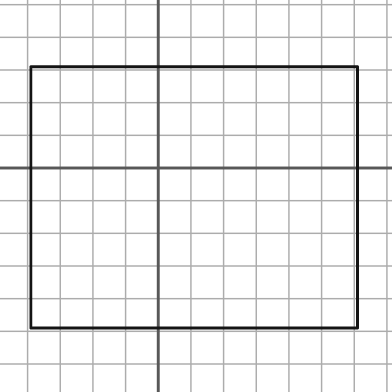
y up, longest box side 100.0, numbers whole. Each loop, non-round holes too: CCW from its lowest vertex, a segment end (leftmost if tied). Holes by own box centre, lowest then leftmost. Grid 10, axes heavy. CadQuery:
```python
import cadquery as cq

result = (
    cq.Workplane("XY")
    .moveTo(-39.0, -49.0)
    .lineTo(61.0, -49.0)
    .lineTo(61.0, 31.0)
    .lineTo(-39.0, 31.0)
    .close()
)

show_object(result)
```